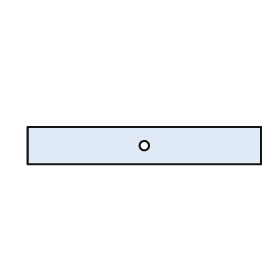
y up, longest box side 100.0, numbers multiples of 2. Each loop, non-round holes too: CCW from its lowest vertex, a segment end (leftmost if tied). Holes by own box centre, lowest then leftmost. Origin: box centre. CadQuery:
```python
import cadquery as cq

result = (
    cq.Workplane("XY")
    .moveTo(-50.0, -8.0)
    .lineTo(50.0, -8.0)
    .lineTo(50.0, 8.0)
    .lineTo(-50.0, 8.0)
    .close()
    .moveTo(0.0, 0.0)
    .circle(2.0)
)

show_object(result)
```